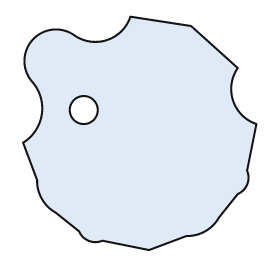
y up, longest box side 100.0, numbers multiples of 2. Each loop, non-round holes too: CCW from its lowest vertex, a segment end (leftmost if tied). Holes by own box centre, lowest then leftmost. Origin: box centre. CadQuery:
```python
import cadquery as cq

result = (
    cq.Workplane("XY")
    .moveTo(4.0, -50.0)
    .lineTo(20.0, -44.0)
    .threePointArc((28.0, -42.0), (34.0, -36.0))
    .lineTo(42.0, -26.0)
    .threePointArc((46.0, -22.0), (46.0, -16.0))
    .lineTo(50.0, 4.0)
    .threePointArc((40.0, 14.0), (42.0, 28.0))
    .lineTo(22.0, 46.0)
    .lineTo(-4.0, 50.0)
    .threePointArc((-14.0, 40.0), (-28.0, 42.0))
    .threePointArc((-46.0, 40.0), (-46.0, 22.0))
    .threePointArc((-42.0, 8.0), (-50.0, -4.0))
    .lineTo(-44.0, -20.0)
    .threePointArc((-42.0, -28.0), (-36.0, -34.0))
    .lineTo(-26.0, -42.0)
    .threePointArc((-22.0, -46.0), (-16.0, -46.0))
    .close()
    .moveTo(-24.0, 10.0)
    .circle(6.0)
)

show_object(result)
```